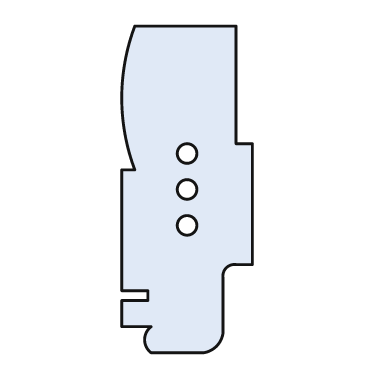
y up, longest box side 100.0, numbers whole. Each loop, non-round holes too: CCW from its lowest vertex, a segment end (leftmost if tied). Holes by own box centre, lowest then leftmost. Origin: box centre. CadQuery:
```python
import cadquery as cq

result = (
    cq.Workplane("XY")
    .moveTo(-11.0, -50.0)
    .lineTo(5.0, -50.0)
    .threePointArc((9.0, -48.0), (11.0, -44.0))
    .lineTo(11.0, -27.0)
    .threePointArc((12.0, -24.0), (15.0, -23.0))
    .lineTo(20.0, -23.0)
    .lineTo(20.0, 14.0)
    .lineTo(15.0, 14.0)
    .lineTo(15.0, 50.0)
    .lineTo(-16.0, 50.0)
    .threePointArc((-20.0, 28.0), (-16.0, 6.0))
    .lineTo(-20.0, 6.0)
    .lineTo(-20.0, -31.0)
    .lineTo(-12.0, -31.0)
    .lineTo(-12.0, -34.0)
    .lineTo(-20.0, -34.0)
    .lineTo(-20.0, -42.0)
    .lineTo(-11.0, -42.0)
    .threePointArc((-13.0, -46.0), (-11.0, -50.0))
    .close()
    .moveTo(0.0, -11.0)
    .circle(3.0)
    .moveTo(0.0, 0.0)
    .circle(3.0)
    .moveTo(0.0, 11.0)
    .circle(3.0)
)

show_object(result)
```